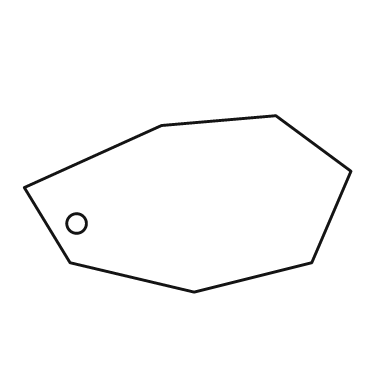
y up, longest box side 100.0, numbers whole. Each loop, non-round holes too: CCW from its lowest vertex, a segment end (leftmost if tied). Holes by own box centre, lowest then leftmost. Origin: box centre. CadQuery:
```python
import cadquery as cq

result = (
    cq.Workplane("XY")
    .moveTo(2.0, -27.0)
    .lineTo(38.0, -18.0)
    .lineTo(50.0, 10.0)
    .lineTo(27.0, 27.0)
    .lineTo(-8.0, 24.0)
    .lineTo(-50.0, 5.0)
    .lineTo(-36.0, -18.0)
    .close()
    .moveTo(-34.0, -6.0)
    .circle(3.0)
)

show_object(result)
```